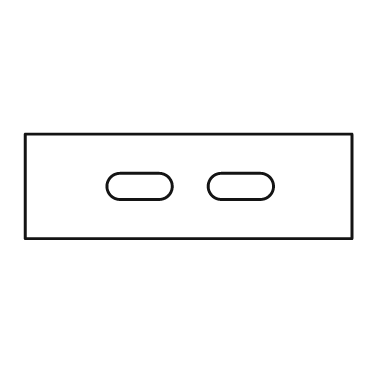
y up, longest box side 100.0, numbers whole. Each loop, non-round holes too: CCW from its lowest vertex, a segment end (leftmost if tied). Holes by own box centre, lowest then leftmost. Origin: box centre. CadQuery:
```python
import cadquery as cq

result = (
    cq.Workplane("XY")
    .moveTo(-50.0, -16.0)
    .lineTo(50.0, -16.0)
    .lineTo(50.0, 16.0)
    .lineTo(-50.0, 16.0)
    .close()
    .moveTo(-21.0, -4.0)
    .lineTo(-9.0, -4.0)
    .threePointArc((-5.0, 0.0), (-9.0, 4.0))
    .lineTo(-21.0, 4.0)
    .threePointArc((-25.0, 0.0), (-21.0, -4.0))
    .close()
    .moveTo(10.0, -4.0)
    .lineTo(22.0, -4.0)
    .threePointArc((26.0, 0.0), (22.0, 4.0))
    .lineTo(10.0, 4.0)
    .threePointArc((6.0, 0.0), (10.0, -4.0))
    .close()
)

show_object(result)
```